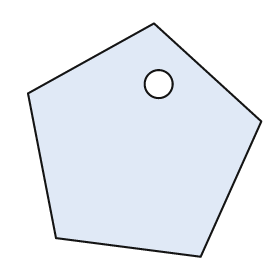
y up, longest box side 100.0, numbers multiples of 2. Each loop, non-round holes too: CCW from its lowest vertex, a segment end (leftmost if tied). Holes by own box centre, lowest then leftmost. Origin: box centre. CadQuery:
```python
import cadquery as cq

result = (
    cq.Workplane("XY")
    .moveTo(24.0, -50.0)
    .lineTo(50.0, 8.0)
    .lineTo(4.0, 50.0)
    .lineTo(-50.0, 20.0)
    .lineTo(-38.0, -42.0)
    .close()
    .moveTo(6.0, 24.0)
    .circle(6.0)
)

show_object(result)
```